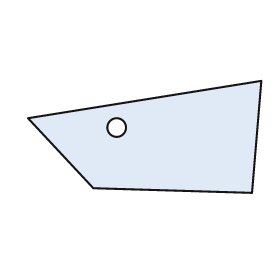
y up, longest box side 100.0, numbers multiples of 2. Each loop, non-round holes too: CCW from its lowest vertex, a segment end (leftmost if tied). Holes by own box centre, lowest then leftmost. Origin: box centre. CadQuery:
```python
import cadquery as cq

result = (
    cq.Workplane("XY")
    .moveTo(46.0, -24.0)
    .lineTo(50.0, 24.0)
    .lineTo(-50.0, 8.0)
    .lineTo(-22.0, -22.0)
    .close()
    .moveTo(-12.0, 4.0)
    .circle(4.0)
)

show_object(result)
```